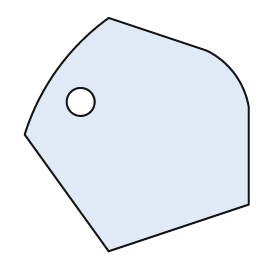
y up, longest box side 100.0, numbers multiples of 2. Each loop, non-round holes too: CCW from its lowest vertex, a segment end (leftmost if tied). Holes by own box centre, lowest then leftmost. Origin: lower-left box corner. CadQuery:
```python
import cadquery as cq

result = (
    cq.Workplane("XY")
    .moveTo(36.0, 0.0)
    .lineTo(96.0, 20.0)
    .lineTo(96.0, 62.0)
    .threePointArc((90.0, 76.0), (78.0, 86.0))
    .lineTo(36.0, 100.0)
    .threePointArc((14.0, 78.0), (0.0, 50.0))
    .close()
    .moveTo(24.0, 64.0)
    .circle(6.0)
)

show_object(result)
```